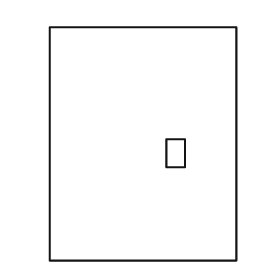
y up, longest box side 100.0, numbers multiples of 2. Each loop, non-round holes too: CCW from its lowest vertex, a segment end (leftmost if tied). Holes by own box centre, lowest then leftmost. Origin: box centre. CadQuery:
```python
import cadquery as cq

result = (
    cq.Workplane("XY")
    .moveTo(-40.0, -50.0)
    .lineTo(40.0, -50.0)
    .lineTo(40.0, 50.0)
    .lineTo(-40.0, 50.0)
    .close()
    .moveTo(10.0, -10.0)
    .lineTo(18.0, -10.0)
    .lineTo(18.0, 2.0)
    .lineTo(10.0, 2.0)
    .close()
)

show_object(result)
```